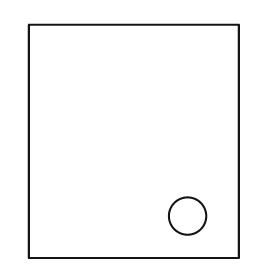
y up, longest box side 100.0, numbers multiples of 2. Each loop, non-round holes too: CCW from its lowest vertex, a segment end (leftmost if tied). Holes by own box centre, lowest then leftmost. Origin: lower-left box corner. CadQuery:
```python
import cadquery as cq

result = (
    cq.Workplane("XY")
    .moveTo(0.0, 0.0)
    .lineTo(90.0, 0.0)
    .lineTo(90.0, 100.0)
    .lineTo(0.0, 100.0)
    .close()
    .moveTo(68.0, 18.0)
    .circle(8.0)
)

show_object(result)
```